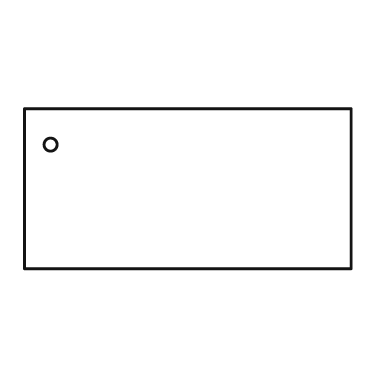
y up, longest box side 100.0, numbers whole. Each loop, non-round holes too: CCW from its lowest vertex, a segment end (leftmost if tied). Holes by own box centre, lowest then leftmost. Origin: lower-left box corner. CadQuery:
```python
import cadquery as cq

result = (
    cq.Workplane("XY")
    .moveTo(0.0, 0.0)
    .lineTo(100.0, 0.0)
    .lineTo(100.0, 49.0)
    .lineTo(0.0, 49.0)
    .close()
    .moveTo(8.0, 38.0)
    .circle(2.0)
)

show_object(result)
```